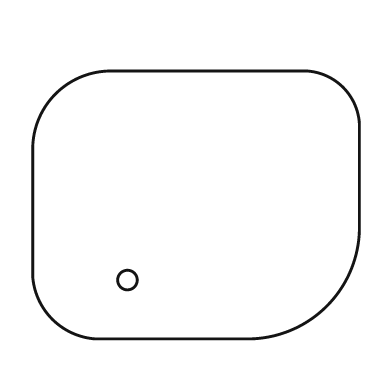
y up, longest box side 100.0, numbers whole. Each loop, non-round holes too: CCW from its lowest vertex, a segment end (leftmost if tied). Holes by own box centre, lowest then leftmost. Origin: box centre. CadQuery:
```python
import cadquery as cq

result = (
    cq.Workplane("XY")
    .moveTo(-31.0, -41.0)
    .lineTo(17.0, -41.0)
    .threePointArc((40.0, -31.0), (50.0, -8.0))
    .lineTo(50.0, 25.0)
    .threePointArc((45.0, 36.0), (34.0, 41.0))
    .lineTo(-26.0, 41.0)
    .threePointArc((-43.0, 34.0), (-50.0, 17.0))
    .lineTo(-50.0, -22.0)
    .threePointArc((-44.0, -35.0), (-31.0, -41.0))
    .close()
    .moveTo(-21.0, -23.0)
    .circle(3.0)
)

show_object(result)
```